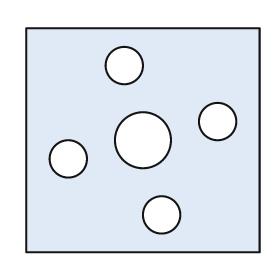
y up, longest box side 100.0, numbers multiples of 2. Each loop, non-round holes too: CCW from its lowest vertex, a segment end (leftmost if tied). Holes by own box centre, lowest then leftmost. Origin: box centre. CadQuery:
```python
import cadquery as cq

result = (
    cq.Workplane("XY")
    .moveTo(-50.0, -48.0)
    .lineTo(50.0, -48.0)
    .lineTo(50.0, 48.0)
    .lineTo(-50.0, 48.0)
    .close()
    .moveTo(8.0, -32.0)
    .circle(8.0)
    .moveTo(-32.0, -8.0)
    .circle(8.0)
    .moveTo(0.0, 0.0)
    .circle(12.0)
    .moveTo(32.0, 8.0)
    .circle(8.0)
    .moveTo(-8.0, 32.0)
    .circle(8.0)
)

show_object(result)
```